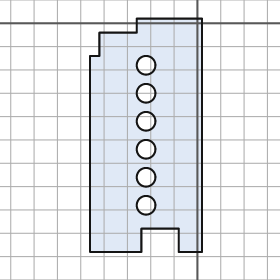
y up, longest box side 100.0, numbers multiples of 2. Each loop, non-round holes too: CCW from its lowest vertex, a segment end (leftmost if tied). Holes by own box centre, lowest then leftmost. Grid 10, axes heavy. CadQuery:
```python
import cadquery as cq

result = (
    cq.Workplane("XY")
    .moveTo(-46.0, -98.0)
    .lineTo(-24.0, -98.0)
    .lineTo(-24.0, -88.0)
    .lineTo(-8.0, -88.0)
    .lineTo(-8.0, -98.0)
    .lineTo(2.0, -98.0)
    .lineTo(2.0, 2.0)
    .lineTo(-26.0, 2.0)
    .lineTo(-26.0, -4.0)
    .lineTo(-42.0, -4.0)
    .lineTo(-42.0, -14.0)
    .lineTo(-46.0, -14.0)
    .close()
    .moveTo(-22.0, -78.0)
    .circle(4.0)
    .moveTo(-22.0, -66.0)
    .circle(4.0)
    .moveTo(-22.0, -54.0)
    .circle(4.0)
    .moveTo(-22.0, -42.0)
    .circle(4.0)
    .moveTo(-22.0, -30.0)
    .circle(4.0)
    .moveTo(-22.0, -18.0)
    .circle(4.0)
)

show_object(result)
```